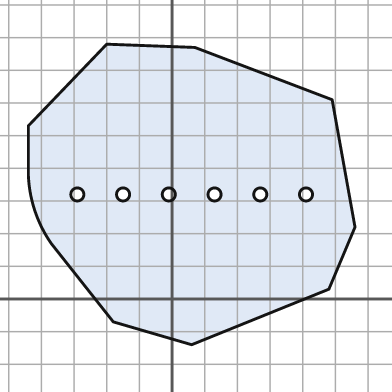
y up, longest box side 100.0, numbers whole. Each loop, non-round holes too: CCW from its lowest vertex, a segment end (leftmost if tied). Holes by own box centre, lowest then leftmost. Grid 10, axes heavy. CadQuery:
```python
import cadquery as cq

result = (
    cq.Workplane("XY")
    .moveTo(6.0, -14.0)
    .lineTo(48.0, 3.0)
    .lineTo(56.0, 22.0)
    .lineTo(49.0, 61.0)
    .lineTo(7.0, 77.0)
    .lineTo(-20.0, 78.0)
    .lineTo(-44.0, 53.0)
    .lineTo(-44.0, 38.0)
    .threePointArc((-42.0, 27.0), (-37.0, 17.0))
    .lineTo(-18.0, -7.0)
    .close()
    .moveTo(-29.0, 32.0)
    .circle(2.0)
    .moveTo(-15.0, 32.0)
    .circle(2.0)
    .moveTo(-1.0, 32.0)
    .circle(2.0)
    .moveTo(13.0, 32.0)
    .circle(2.0)
    .moveTo(27.0, 32.0)
    .circle(2.0)
    .moveTo(41.0, 32.0)
    .circle(2.0)
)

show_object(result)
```